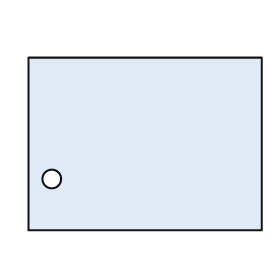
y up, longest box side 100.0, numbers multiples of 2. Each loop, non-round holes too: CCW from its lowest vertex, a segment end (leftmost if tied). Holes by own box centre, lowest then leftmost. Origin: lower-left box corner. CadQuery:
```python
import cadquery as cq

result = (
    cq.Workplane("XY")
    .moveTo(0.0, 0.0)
    .lineTo(100.0, 0.0)
    .lineTo(100.0, 74.0)
    .lineTo(0.0, 74.0)
    .close()
    .moveTo(10.0, 22.0)
    .circle(4.0)
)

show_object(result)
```